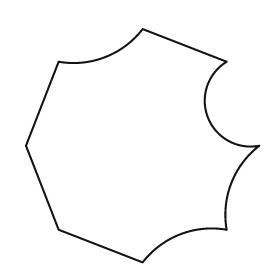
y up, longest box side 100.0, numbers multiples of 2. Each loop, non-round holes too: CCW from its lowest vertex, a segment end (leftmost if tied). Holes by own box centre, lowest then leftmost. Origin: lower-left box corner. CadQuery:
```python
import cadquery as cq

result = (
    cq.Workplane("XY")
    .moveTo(50.0, 0.0)
    .threePointArc((66.0, 12.0), (86.0, 14.0))
    .threePointArc((88.0, 34.0), (100.0, 50.0))
    .threePointArc((78.0, 62.0), (86.0, 86.0))
    .lineTo(50.0, 100.0)
    .threePointArc((34.0, 88.0), (14.0, 86.0))
    .lineTo(0.0, 50.0)
    .lineTo(14.0, 14.0)
    .close()
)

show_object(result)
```